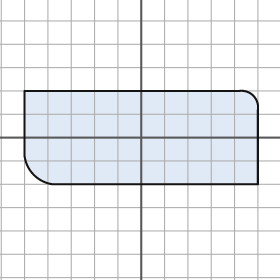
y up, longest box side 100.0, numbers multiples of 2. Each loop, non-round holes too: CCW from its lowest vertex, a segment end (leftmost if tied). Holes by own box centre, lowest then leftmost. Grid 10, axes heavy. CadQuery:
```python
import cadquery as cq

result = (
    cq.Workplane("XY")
    .moveTo(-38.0, -20.0)
    .lineTo(50.0, -20.0)
    .lineTo(50.0, 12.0)
    .threePointArc((48.0, 18.0), (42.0, 20.0))
    .lineTo(-50.0, 20.0)
    .lineTo(-50.0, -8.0)
    .threePointArc((-46.0, -16.0), (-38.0, -20.0))
    .close()
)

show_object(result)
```